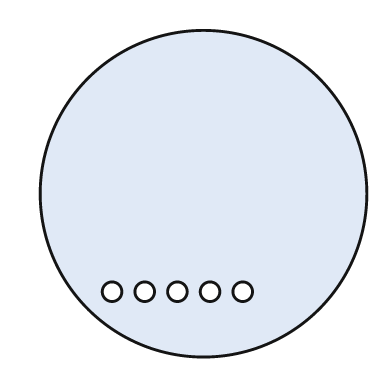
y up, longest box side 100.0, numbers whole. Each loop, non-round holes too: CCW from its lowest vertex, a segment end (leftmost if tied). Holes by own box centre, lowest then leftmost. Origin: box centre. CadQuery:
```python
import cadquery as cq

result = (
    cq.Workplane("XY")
    .moveTo(0.0, 0.0)
    .circle(50.0)
    .moveTo(-28.0, -30.0)
    .circle(3.0)
    .moveTo(-18.0, -30.0)
    .circle(3.0)
    .moveTo(-8.0, -30.0)
    .circle(3.0)
    .moveTo(2.0, -30.0)
    .circle(3.0)
    .moveTo(12.0, -30.0)
    .circle(3.0)
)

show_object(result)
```